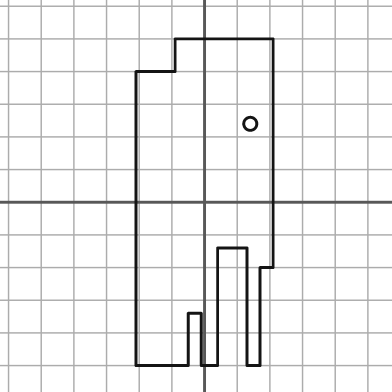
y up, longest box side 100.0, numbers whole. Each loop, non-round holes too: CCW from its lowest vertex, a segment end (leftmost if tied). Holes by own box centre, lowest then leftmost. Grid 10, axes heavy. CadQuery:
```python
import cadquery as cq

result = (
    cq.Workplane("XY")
    .moveTo(-21.0, -50.0)
    .lineTo(-5.0, -50.0)
    .lineTo(-5.0, -34.0)
    .lineTo(-1.0, -34.0)
    .lineTo(-1.0, -50.0)
    .lineTo(4.0, -50.0)
    .lineTo(4.0, -14.0)
    .lineTo(13.0, -14.0)
    .lineTo(13.0, -50.0)
    .lineTo(17.0, -50.0)
    .lineTo(17.0, -20.0)
    .lineTo(21.0, -20.0)
    .lineTo(21.0, 50.0)
    .lineTo(-9.0, 50.0)
    .lineTo(-9.0, 40.0)
    .lineTo(-21.0, 40.0)
    .close()
    .moveTo(14.0, 24.0)
    .circle(2.0)
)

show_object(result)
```